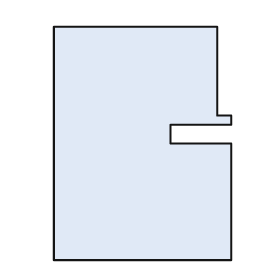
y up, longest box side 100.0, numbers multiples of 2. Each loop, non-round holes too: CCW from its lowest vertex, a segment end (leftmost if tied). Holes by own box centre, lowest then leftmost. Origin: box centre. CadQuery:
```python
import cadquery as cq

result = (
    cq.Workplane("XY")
    .moveTo(-38.0, -50.0)
    .lineTo(38.0, -50.0)
    .lineTo(38.0, 0.0)
    .lineTo(12.0, 0.0)
    .lineTo(12.0, 8.0)
    .lineTo(38.0, 8.0)
    .lineTo(38.0, 12.0)
    .lineTo(32.0, 12.0)
    .lineTo(32.0, 50.0)
    .lineTo(-38.0, 50.0)
    .close()
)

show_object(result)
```